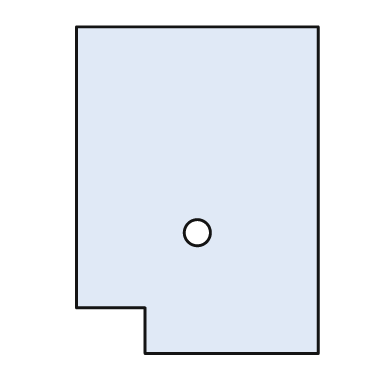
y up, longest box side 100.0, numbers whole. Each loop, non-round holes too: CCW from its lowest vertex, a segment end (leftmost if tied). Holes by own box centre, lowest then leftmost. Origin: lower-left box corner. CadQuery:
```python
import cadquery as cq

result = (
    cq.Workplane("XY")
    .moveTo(21.0, 0.0)
    .lineTo(74.0, 0.0)
    .lineTo(74.0, 100.0)
    .lineTo(0.0, 100.0)
    .lineTo(0.0, 14.0)
    .lineTo(21.0, 14.0)
    .close()
    .moveTo(37.0, 37.0)
    .circle(4.0)
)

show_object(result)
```